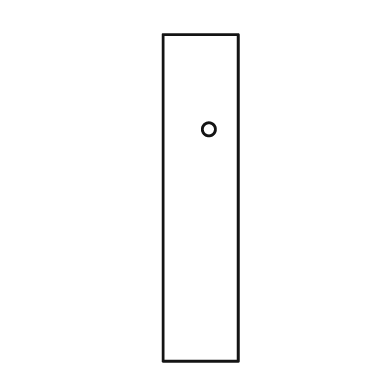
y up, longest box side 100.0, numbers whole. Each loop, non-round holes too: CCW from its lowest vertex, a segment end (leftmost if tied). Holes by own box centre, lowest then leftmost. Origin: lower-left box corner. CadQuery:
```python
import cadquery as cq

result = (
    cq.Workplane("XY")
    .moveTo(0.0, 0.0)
    .lineTo(23.0, 0.0)
    .lineTo(23.0, 100.0)
    .lineTo(0.0, 100.0)
    .close()
    .moveTo(14.0, 71.0)
    .circle(2.0)
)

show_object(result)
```